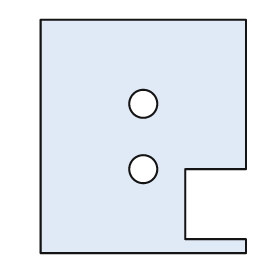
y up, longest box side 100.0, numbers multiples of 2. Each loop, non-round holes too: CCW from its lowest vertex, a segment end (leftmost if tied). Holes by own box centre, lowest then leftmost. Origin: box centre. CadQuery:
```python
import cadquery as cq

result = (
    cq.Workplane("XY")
    .moveTo(-44.0, -50.0)
    .lineTo(44.0, -50.0)
    .lineTo(44.0, -44.0)
    .lineTo(18.0, -44.0)
    .lineTo(18.0, -14.0)
    .lineTo(44.0, -14.0)
    .lineTo(44.0, 50.0)
    .lineTo(-44.0, 50.0)
    .close()
    .moveTo(0.0, -14.0)
    .circle(6.0)
    .moveTo(0.0, 14.0)
    .circle(6.0)
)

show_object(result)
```